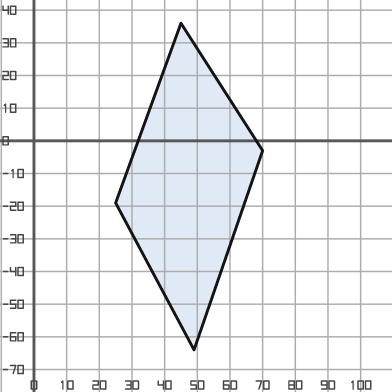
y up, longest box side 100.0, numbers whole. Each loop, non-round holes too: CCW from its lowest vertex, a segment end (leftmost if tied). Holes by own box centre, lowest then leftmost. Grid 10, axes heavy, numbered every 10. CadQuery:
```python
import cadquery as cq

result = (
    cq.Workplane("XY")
    .moveTo(49.0, -64.0)
    .lineTo(70.0, -3.0)
    .lineTo(45.0, 36.0)
    .lineTo(25.0, -19.0)
    .close()
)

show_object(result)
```